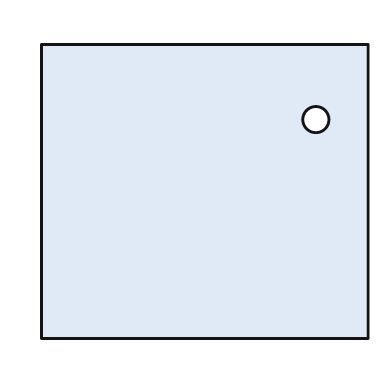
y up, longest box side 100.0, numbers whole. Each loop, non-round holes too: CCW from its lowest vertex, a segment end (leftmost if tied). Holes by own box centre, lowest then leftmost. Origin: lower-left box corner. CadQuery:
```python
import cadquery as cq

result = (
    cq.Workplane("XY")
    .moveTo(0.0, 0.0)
    .lineTo(100.0, 0.0)
    .lineTo(100.0, 90.0)
    .lineTo(0.0, 90.0)
    .close()
    .moveTo(84.0, 67.0)
    .circle(4.0)
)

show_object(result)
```